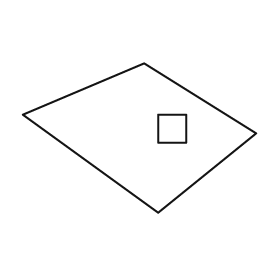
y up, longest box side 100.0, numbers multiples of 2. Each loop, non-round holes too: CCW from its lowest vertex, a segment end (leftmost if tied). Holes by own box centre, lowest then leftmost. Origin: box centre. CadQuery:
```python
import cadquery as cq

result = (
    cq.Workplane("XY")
    .moveTo(8.0, -32.0)
    .lineTo(50.0, 2.0)
    .lineTo(2.0, 32.0)
    .lineTo(-50.0, 10.0)
    .close()
    .moveTo(8.0, -2.0)
    .lineTo(20.0, -2.0)
    .lineTo(20.0, 10.0)
    .lineTo(8.0, 10.0)
    .close()
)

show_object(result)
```